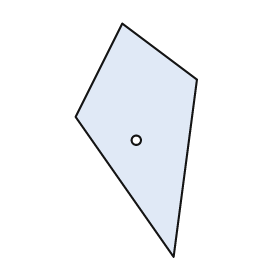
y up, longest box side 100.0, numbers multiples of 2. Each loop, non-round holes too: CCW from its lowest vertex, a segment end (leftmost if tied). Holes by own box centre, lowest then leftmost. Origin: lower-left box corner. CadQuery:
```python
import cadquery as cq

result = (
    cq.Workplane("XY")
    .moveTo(42.0, 0.0)
    .lineTo(52.0, 76.0)
    .lineTo(20.0, 100.0)
    .lineTo(0.0, 60.0)
    .close()
    .moveTo(26.0, 50.0)
    .circle(2.0)
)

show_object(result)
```